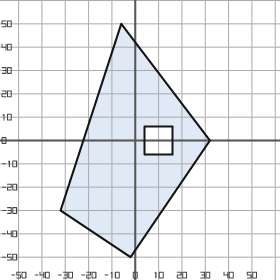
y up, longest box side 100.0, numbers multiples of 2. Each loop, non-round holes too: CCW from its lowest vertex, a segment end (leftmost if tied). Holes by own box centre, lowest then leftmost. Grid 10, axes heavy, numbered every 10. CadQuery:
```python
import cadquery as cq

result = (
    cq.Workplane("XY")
    .moveTo(-2.0, -50.0)
    .lineTo(32.0, 0.0)
    .lineTo(-6.0, 50.0)
    .lineTo(-32.0, -30.0)
    .close()
    .moveTo(4.0, -6.0)
    .lineTo(16.0, -6.0)
    .lineTo(16.0, 6.0)
    .lineTo(4.0, 6.0)
    .close()
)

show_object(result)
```